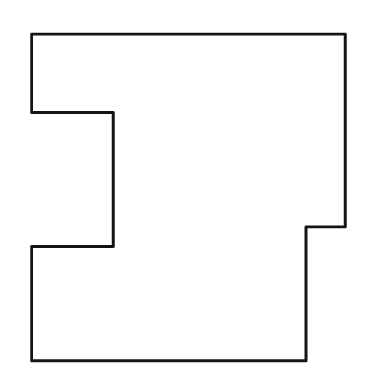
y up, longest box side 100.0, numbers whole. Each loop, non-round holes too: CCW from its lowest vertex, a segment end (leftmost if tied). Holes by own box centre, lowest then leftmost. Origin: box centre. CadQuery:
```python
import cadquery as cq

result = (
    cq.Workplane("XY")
    .moveTo(-48.0, -50.0)
    .lineTo(36.0, -50.0)
    .lineTo(36.0, -9.0)
    .lineTo(48.0, -9.0)
    .lineTo(48.0, 50.0)
    .lineTo(-48.0, 50.0)
    .lineTo(-48.0, 26.0)
    .lineTo(-23.0, 26.0)
    .lineTo(-23.0, -15.0)
    .lineTo(-48.0, -15.0)
    .close()
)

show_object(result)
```